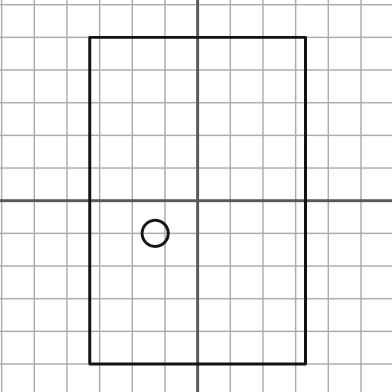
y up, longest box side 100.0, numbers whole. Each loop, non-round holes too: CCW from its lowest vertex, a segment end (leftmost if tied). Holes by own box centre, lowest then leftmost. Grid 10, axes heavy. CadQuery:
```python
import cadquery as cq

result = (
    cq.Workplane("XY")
    .moveTo(-33.0, -50.0)
    .lineTo(33.0, -50.0)
    .lineTo(33.0, 50.0)
    .lineTo(-33.0, 50.0)
    .close()
    .moveTo(-13.0, -10.0)
    .circle(4.0)
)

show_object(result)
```